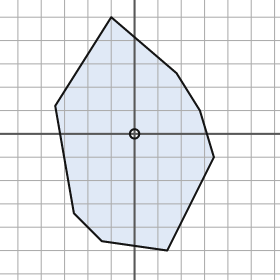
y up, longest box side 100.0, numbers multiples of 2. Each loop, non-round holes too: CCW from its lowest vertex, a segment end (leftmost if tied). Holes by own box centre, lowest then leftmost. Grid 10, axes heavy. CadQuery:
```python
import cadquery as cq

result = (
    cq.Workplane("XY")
    .moveTo(14.0, -50.0)
    .lineTo(34.0, -10.0)
    .lineTo(28.0, 10.0)
    .lineTo(18.0, 26.0)
    .lineTo(-10.0, 50.0)
    .lineTo(-34.0, 12.0)
    .lineTo(-26.0, -34.0)
    .lineTo(-14.0, -46.0)
    .close()
    .moveTo(0.0, 0.0)
    .circle(2.0)
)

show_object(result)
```